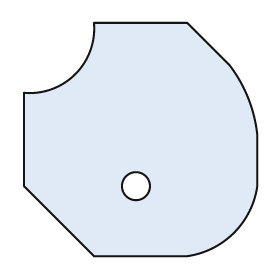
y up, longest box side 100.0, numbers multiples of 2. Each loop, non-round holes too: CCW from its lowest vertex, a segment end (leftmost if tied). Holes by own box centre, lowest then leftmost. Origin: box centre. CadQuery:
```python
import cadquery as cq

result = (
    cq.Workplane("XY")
    .moveTo(-20.0, -50.0)
    .lineTo(20.0, -50.0)
    .threePointArc((40.0, -40.0), (50.0, -20.0))
    .lineTo(50.0, 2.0)
    .threePointArc((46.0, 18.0), (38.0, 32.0))
    .lineTo(20.0, 50.0)
    .lineTo(-20.0, 50.0)
    .threePointArc((-28.0, 28.0), (-50.0, 20.0))
    .lineTo(-50.0, -20.0)
    .close()
    .moveTo(-2.0, -20.0)
    .circle(6.0)
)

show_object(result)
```